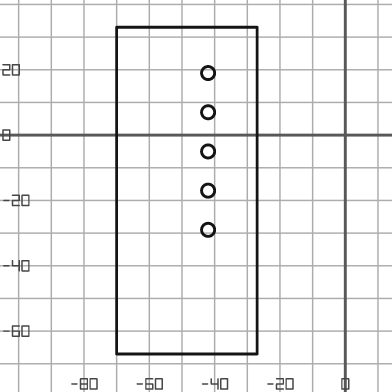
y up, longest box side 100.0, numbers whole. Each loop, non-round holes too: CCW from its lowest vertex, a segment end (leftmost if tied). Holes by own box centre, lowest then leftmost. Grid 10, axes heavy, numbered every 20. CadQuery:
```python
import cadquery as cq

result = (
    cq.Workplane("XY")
    .moveTo(-70.0, -67.0)
    .lineTo(-27.0, -67.0)
    .lineTo(-27.0, 33.0)
    .lineTo(-70.0, 33.0)
    .close()
    .moveTo(-42.0, -29.0)
    .circle(2.0)
    .moveTo(-42.0, -17.0)
    .circle(2.0)
    .moveTo(-42.0, -5.0)
    .circle(2.0)
    .moveTo(-42.0, 7.0)
    .circle(2.0)
    .moveTo(-42.0, 19.0)
    .circle(2.0)
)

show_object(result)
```